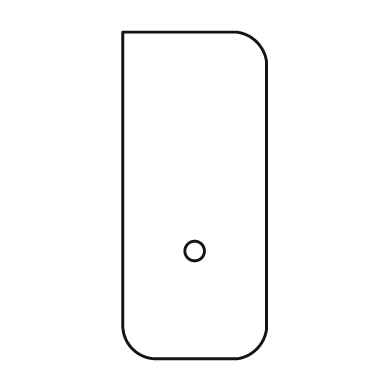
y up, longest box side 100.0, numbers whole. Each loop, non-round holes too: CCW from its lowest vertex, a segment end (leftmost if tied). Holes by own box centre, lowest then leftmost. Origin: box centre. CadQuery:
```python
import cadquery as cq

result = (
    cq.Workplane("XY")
    .moveTo(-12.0, -50.0)
    .lineTo(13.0, -50.0)
    .threePointArc((19.0, -47.0), (22.0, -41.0))
    .lineTo(22.0, 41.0)
    .threePointArc((19.0, 47.0), (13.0, 50.0))
    .lineTo(-22.0, 50.0)
    .lineTo(-22.0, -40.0)
    .threePointArc((-19.0, -47.0), (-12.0, -50.0))
    .close()
    .moveTo(0.0, -17.0)
    .circle(3.0)
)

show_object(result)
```